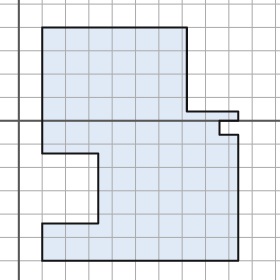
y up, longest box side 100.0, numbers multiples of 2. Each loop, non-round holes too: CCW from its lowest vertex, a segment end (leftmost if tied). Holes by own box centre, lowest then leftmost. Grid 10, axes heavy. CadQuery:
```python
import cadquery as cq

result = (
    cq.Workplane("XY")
    .moveTo(10.0, -60.0)
    .lineTo(94.0, -60.0)
    .lineTo(94.0, -6.0)
    .lineTo(86.0, -6.0)
    .lineTo(86.0, 0.0)
    .lineTo(94.0, 0.0)
    .lineTo(94.0, 4.0)
    .lineTo(72.0, 4.0)
    .lineTo(72.0, 40.0)
    .lineTo(10.0, 40.0)
    .lineTo(10.0, -14.0)
    .lineTo(34.0, -14.0)
    .lineTo(34.0, -44.0)
    .lineTo(10.0, -44.0)
    .close()
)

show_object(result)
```